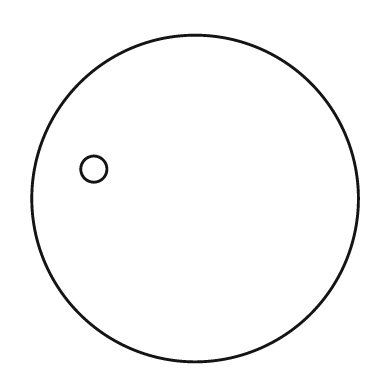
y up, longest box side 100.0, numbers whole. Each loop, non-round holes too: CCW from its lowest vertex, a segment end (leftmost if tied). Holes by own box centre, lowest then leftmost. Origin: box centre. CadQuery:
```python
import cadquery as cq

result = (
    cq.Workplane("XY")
    .moveTo(0.0, 0.0)
    .circle(50.0)
    .moveTo(-31.0, 9.0)
    .circle(4.0)
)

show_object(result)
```